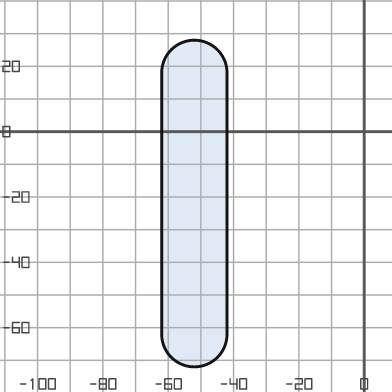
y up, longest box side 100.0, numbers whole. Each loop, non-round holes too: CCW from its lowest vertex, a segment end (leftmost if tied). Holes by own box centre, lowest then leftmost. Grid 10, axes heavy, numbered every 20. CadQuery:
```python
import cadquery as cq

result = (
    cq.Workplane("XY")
    .moveTo(-62.0, -62.0)
    .threePointArc((-52.0, -72.0), (-42.0, -62.0))
    .lineTo(-42.0, 18.0)
    .threePointArc((-52.0, 28.0), (-62.0, 18.0))
    .close()
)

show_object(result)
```